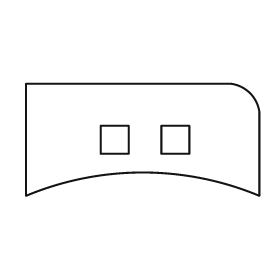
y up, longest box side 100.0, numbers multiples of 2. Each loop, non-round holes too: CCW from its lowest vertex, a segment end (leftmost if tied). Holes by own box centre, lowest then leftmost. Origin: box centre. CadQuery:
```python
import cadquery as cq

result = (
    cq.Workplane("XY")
    .moveTo(-50.0, -24.0)
    .threePointArc((0.0, -14.0), (50.0, -24.0))
    .lineTo(50.0, 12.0)
    .threePointArc((46.0, 20.0), (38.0, 24.0))
    .lineTo(-50.0, 24.0)
    .close()
    .moveTo(-18.0, -6.0)
    .lineTo(-6.0, -6.0)
    .lineTo(-6.0, 6.0)
    .lineTo(-18.0, 6.0)
    .close()
    .moveTo(8.0, -6.0)
    .lineTo(20.0, -6.0)
    .lineTo(20.0, 6.0)
    .lineTo(8.0, 6.0)
    .close()
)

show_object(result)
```